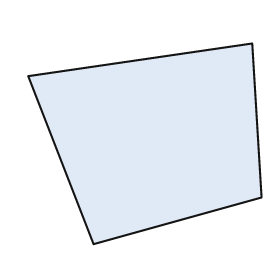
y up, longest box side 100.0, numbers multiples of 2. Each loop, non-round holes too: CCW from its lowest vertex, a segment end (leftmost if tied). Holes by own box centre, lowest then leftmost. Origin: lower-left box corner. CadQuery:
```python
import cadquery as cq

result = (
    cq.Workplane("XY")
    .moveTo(28.0, 0.0)
    .lineTo(100.0, 20.0)
    .lineTo(96.0, 86.0)
    .lineTo(0.0, 72.0)
    .close()
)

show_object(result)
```